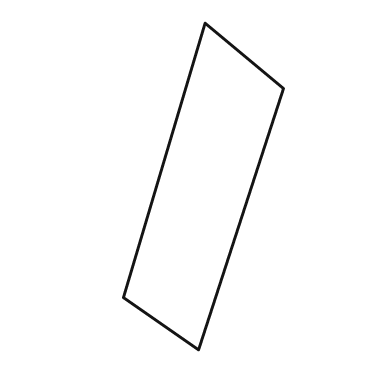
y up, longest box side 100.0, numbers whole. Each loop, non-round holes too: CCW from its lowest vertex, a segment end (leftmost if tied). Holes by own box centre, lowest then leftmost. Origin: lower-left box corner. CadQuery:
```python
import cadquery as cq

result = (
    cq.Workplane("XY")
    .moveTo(23.0, 0.0)
    .lineTo(49.0, 80.0)
    .lineTo(25.0, 100.0)
    .lineTo(0.0, 16.0)
    .close()
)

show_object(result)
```